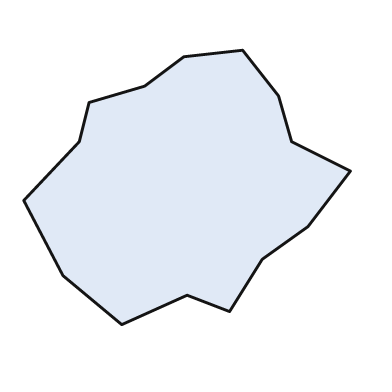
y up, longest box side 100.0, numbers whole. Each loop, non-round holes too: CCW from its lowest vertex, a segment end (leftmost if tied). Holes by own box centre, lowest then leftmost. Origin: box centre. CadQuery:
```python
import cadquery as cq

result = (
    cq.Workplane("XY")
    .moveTo(-20.0, -42.0)
    .lineTo(0.0, -33.0)
    .lineTo(13.0, -38.0)
    .lineTo(23.0, -22.0)
    .lineTo(37.0, -12.0)
    .lineTo(50.0, 5.0)
    .lineTo(32.0, 14.0)
    .lineTo(28.0, 28.0)
    .lineTo(17.0, 42.0)
    .lineTo(-1.0, 40.0)
    .lineTo(-13.0, 31.0)
    .lineTo(-30.0, 26.0)
    .lineTo(-33.0, 14.0)
    .lineTo(-50.0, -4.0)
    .lineTo(-38.0, -27.0)
    .close()
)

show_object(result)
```